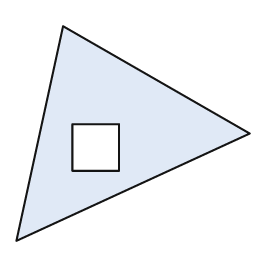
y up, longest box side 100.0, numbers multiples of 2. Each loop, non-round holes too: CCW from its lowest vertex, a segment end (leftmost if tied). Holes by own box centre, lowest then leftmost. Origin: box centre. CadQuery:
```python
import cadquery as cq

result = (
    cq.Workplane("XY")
    .moveTo(-50.0, -46.0)
    .lineTo(50.0, 0.0)
    .lineTo(-30.0, 46.0)
    .close()
    .moveTo(-26.0, -16.0)
    .lineTo(-6.0, -16.0)
    .lineTo(-6.0, 4.0)
    .lineTo(-26.0, 4.0)
    .close()
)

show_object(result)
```